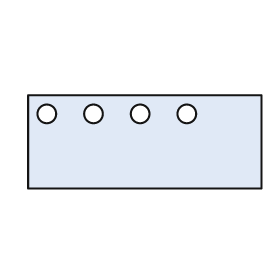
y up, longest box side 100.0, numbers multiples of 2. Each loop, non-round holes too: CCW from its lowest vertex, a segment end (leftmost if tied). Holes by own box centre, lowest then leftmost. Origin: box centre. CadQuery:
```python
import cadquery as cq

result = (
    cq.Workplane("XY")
    .moveTo(-50.0, -20.0)
    .lineTo(50.0, -20.0)
    .lineTo(50.0, 20.0)
    .lineTo(-50.0, 20.0)
    .close()
    .moveTo(-42.0, 12.0)
    .circle(4.0)
    .moveTo(-22.0, 12.0)
    .circle(4.0)
    .moveTo(-2.0, 12.0)
    .circle(4.0)
    .moveTo(18.0, 12.0)
    .circle(4.0)
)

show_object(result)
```